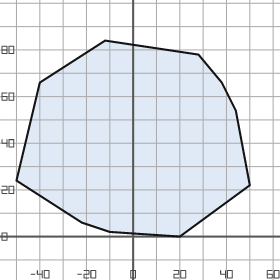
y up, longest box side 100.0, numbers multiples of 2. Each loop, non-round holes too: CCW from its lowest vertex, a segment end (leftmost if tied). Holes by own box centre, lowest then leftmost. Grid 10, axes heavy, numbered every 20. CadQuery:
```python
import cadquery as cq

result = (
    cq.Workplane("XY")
    .moveTo(20.0, 0.0)
    .lineTo(50.0, 22.0)
    .lineTo(44.0, 54.0)
    .lineTo(38.0, 66.0)
    .lineTo(28.0, 78.0)
    .lineTo(-12.0, 84.0)
    .lineTo(-40.0, 66.0)
    .lineTo(-50.0, 24.0)
    .lineTo(-22.0, 6.0)
    .lineTo(-10.0, 2.0)
    .close()
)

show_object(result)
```